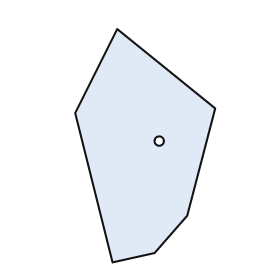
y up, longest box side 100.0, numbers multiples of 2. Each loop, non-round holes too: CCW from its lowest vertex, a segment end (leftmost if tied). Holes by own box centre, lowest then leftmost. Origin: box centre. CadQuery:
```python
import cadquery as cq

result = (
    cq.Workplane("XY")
    .moveTo(-14.0, -50.0)
    .lineTo(4.0, -46.0)
    .lineTo(18.0, -30.0)
    .lineTo(30.0, 16.0)
    .lineTo(-12.0, 50.0)
    .lineTo(-30.0, 14.0)
    .close()
    .moveTo(6.0, 2.0)
    .circle(2.0)
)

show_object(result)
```